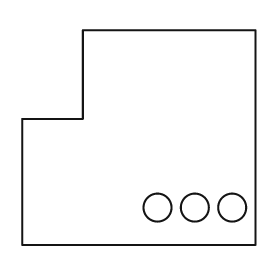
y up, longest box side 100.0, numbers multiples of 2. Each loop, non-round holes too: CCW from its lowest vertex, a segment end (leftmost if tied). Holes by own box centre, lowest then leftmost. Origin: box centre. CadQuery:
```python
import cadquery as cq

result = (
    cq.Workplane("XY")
    .moveTo(-50.0, -46.0)
    .lineTo(50.0, -46.0)
    .lineTo(50.0, 46.0)
    .lineTo(-24.0, 46.0)
    .lineTo(-24.0, 8.0)
    .lineTo(-50.0, 8.0)
    .close()
    .moveTo(8.0, -30.0)
    .circle(6.0)
    .moveTo(24.0, -30.0)
    .circle(6.0)
    .moveTo(40.0, -30.0)
    .circle(6.0)
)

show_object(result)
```